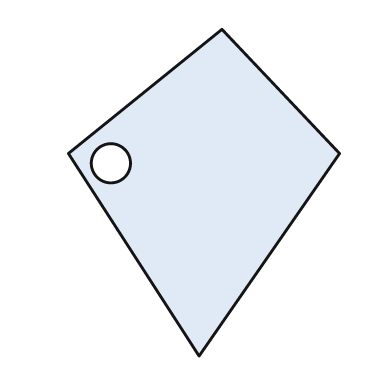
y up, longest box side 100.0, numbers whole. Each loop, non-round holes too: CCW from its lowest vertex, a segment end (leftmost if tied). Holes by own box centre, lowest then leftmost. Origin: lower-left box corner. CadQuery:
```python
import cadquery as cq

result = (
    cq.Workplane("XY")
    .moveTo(40.0, 0.0)
    .lineTo(83.0, 62.0)
    .lineTo(47.0, 100.0)
    .lineTo(0.0, 62.0)
    .close()
    .moveTo(13.0, 59.0)
    .circle(6.0)
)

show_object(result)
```